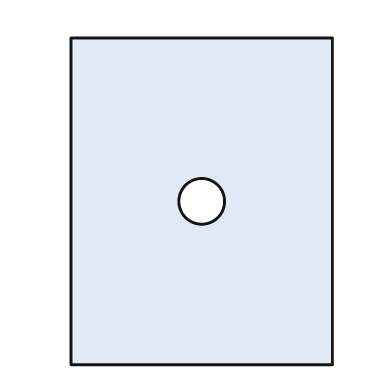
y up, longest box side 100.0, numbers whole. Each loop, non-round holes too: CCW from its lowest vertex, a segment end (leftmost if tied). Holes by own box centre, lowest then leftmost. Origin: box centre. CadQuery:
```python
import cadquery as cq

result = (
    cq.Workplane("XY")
    .moveTo(-40.0, -50.0)
    .lineTo(40.0, -50.0)
    .lineTo(40.0, 50.0)
    .lineTo(-40.0, 50.0)
    .close()
    .moveTo(0.0, 0.0)
    .circle(7.0)
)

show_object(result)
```